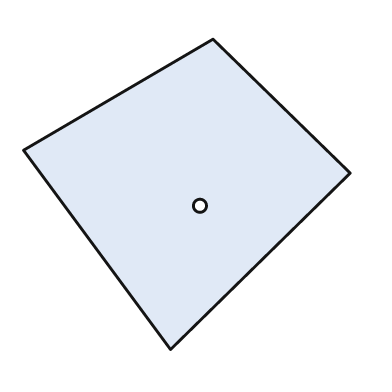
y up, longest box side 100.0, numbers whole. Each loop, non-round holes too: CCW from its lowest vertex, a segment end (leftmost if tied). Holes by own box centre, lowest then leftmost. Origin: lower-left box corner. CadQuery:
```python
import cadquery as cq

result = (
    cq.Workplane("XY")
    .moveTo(45.0, 0.0)
    .lineTo(100.0, 54.0)
    .lineTo(58.0, 95.0)
    .lineTo(0.0, 61.0)
    .close()
    .moveTo(54.0, 44.0)
    .circle(2.0)
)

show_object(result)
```